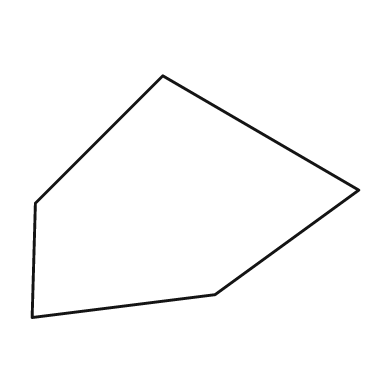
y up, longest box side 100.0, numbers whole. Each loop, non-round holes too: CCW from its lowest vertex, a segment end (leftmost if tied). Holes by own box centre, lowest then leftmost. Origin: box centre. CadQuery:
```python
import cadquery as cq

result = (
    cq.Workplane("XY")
    .moveTo(-50.0, -37.0)
    .lineTo(6.0, -30.0)
    .lineTo(50.0, 2.0)
    .lineTo(-10.0, 37.0)
    .lineTo(-49.0, -2.0)
    .close()
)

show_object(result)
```